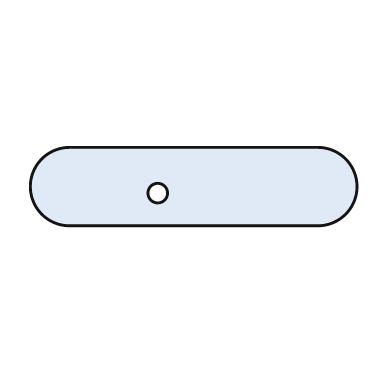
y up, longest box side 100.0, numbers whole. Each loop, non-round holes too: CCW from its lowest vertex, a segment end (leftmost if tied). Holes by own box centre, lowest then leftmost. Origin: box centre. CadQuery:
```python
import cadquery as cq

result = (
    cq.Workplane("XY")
    .moveTo(-38.0, -12.0)
    .lineTo(38.0, -12.0)
    .threePointArc((50.0, 0.0), (38.0, 12.0))
    .lineTo(-38.0, 12.0)
    .threePointArc((-50.0, 0.0), (-38.0, -12.0))
    .close()
    .moveTo(-11.0, -2.0)
    .circle(3.0)
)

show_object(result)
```